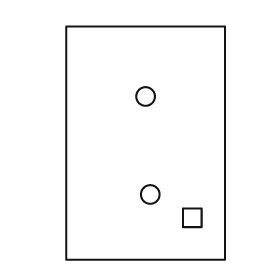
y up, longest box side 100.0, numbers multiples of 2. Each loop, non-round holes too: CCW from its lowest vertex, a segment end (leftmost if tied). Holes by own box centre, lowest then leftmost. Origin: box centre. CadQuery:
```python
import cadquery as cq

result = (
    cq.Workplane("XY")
    .moveTo(-34.0, -50.0)
    .lineTo(34.0, -50.0)
    .lineTo(34.0, 50.0)
    .lineTo(-34.0, 50.0)
    .close()
    .moveTo(16.0, -36.0)
    .lineTo(24.0, -36.0)
    .lineTo(24.0, -28.0)
    .lineTo(16.0, -28.0)
    .close()
    .moveTo(2.0, -22.0)
    .circle(4.0)
    .moveTo(0.0, 20.0)
    .circle(4.0)
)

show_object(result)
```